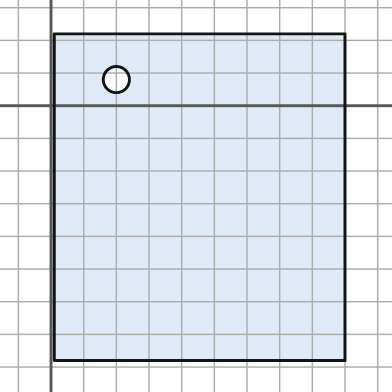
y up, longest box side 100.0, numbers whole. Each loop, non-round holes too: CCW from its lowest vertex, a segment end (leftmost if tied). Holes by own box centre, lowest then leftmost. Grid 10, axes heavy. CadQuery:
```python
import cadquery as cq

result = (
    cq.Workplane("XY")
    .moveTo(1.0, -78.0)
    .lineTo(90.0, -78.0)
    .lineTo(90.0, 22.0)
    .lineTo(1.0, 22.0)
    .close()
    .moveTo(20.0, 8.0)
    .circle(4.0)
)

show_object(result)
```